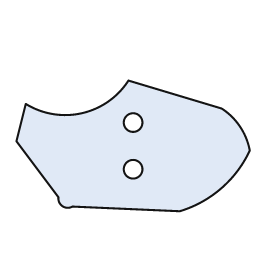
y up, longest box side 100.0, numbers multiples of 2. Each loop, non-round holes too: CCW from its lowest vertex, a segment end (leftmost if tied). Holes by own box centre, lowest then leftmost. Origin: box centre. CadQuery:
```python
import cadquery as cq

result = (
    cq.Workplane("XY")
    .moveTo(20.0, -28.0)
    .threePointArc((38.0, -18.0), (50.0, -2.0))
    .threePointArc((46.0, 8.0), (38.0, 16.0))
    .lineTo(-2.0, 28.0)
    .threePointArc((-22.0, 14.0), (-46.0, 18.0))
    .lineTo(-50.0, 2.0)
    .lineTo(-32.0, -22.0)
    .threePointArc((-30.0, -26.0), (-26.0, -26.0))
    .close()
    .moveTo(0.0, -10.0)
    .circle(4.0)
    .moveTo(0.0, 10.0)
    .circle(4.0)
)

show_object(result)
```